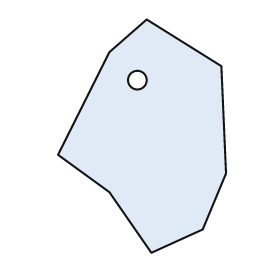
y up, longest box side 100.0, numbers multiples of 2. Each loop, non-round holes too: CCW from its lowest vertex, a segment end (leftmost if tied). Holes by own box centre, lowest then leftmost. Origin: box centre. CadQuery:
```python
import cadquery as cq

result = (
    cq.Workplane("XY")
    .moveTo(4.0, -50.0)
    .lineTo(26.0, -40.0)
    .lineTo(36.0, -16.0)
    .lineTo(34.0, 30.0)
    .lineTo(2.0, 50.0)
    .lineTo(-14.0, 36.0)
    .lineTo(-36.0, -8.0)
    .lineTo(-14.0, -24.0)
    .close()
    .moveTo(-2.0, 24.0)
    .circle(4.0)
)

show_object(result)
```